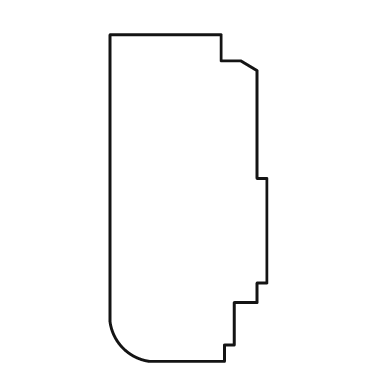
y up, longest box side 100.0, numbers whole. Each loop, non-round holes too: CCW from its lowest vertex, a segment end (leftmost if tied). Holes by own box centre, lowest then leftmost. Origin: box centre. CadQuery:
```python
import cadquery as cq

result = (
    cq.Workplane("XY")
    .moveTo(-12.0, -50.0)
    .lineTo(11.0, -50.0)
    .lineTo(11.0, -45.0)
    .lineTo(14.0, -45.0)
    .lineTo(14.0, -32.0)
    .lineTo(21.0, -32.0)
    .lineTo(21.0, -26.0)
    .lineTo(24.0, -26.0)
    .lineTo(24.0, 6.0)
    .lineTo(21.0, 6.0)
    .lineTo(21.0, 39.0)
    .lineTo(16.0, 42.0)
    .lineTo(10.0, 42.0)
    .lineTo(10.0, 50.0)
    .lineTo(-24.0, 50.0)
    .lineTo(-24.0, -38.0)
    .threePointArc((-20.0, -46.0), (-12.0, -50.0))
    .close()
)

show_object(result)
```